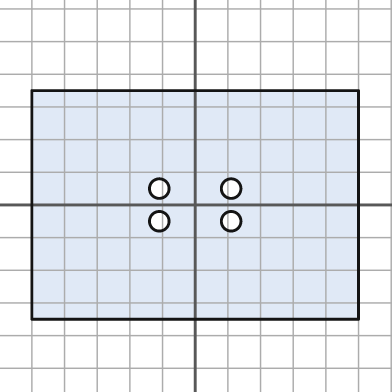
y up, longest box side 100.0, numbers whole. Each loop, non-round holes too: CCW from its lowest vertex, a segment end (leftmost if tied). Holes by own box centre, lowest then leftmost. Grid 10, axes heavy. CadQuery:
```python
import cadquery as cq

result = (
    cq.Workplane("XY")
    .moveTo(-50.0, -35.0)
    .lineTo(50.0, -35.0)
    .lineTo(50.0, 35.0)
    .lineTo(-50.0, 35.0)
    .close()
    .moveTo(-11.0, -5.0)
    .circle(3.0)
    .moveTo(11.0, -5.0)
    .circle(3.0)
    .moveTo(-11.0, 5.0)
    .circle(3.0)
    .moveTo(11.0, 5.0)
    .circle(3.0)
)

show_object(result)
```